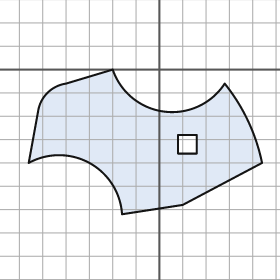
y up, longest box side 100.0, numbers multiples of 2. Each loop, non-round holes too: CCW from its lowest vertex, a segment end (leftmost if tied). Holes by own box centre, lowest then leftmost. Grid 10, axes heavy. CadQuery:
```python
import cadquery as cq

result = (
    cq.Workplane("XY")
    .moveTo(-16.0, -62.0)
    .lineTo(10.0, -58.0)
    .lineTo(44.0, -40.0)
    .threePointArc((38.0, -22.0), (28.0, -6.0))
    .threePointArc((2.0, -18.0), (-20.0, 0.0))
    .lineTo(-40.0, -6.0)
    .threePointArc((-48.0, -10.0), (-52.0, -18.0))
    .lineTo(-56.0, -40.0)
    .threePointArc((-30.0, -40.0), (-16.0, -62.0))
    .close()
    .moveTo(8.0, -36.0)
    .lineTo(16.0, -36.0)
    .lineTo(16.0, -28.0)
    .lineTo(8.0, -28.0)
    .close()
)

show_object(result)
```